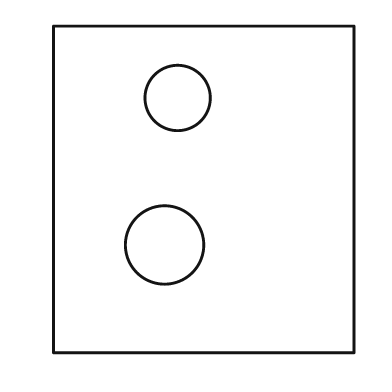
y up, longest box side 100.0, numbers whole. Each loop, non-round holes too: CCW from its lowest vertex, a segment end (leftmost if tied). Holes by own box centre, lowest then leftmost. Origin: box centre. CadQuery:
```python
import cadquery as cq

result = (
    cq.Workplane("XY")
    .moveTo(-46.0, -50.0)
    .lineTo(46.0, -50.0)
    .lineTo(46.0, 50.0)
    .lineTo(-46.0, 50.0)
    .close()
    .moveTo(-12.0, -17.0)
    .circle(12.0)
    .moveTo(-8.0, 28.0)
    .circle(10.0)
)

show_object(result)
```